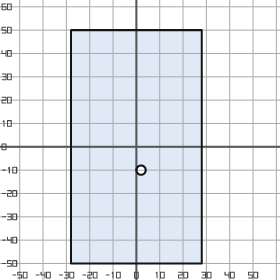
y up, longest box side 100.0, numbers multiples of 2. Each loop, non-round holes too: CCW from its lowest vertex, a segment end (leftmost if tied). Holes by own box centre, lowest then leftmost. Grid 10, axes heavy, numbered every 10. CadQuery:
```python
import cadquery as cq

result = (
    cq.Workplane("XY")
    .moveTo(-28.0, -50.0)
    .lineTo(28.0, -50.0)
    .lineTo(28.0, 50.0)
    .lineTo(-28.0, 50.0)
    .close()
    .moveTo(2.0, -10.0)
    .circle(2.0)
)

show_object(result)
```